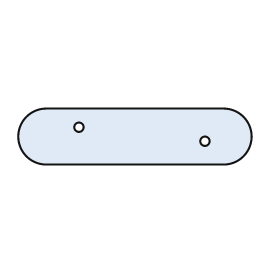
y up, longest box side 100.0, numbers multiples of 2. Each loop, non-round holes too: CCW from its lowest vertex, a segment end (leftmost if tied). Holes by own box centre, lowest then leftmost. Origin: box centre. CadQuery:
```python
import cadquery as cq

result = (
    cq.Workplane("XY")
    .moveTo(-38.0, -12.0)
    .lineTo(38.0, -12.0)
    .threePointArc((50.0, 0.0), (38.0, 12.0))
    .lineTo(-38.0, 12.0)
    .threePointArc((-50.0, 0.0), (-38.0, -12.0))
    .close()
    .moveTo(30.0, -2.0)
    .circle(2.0)
    .moveTo(-24.0, 4.0)
    .circle(2.0)
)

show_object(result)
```